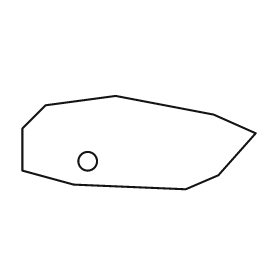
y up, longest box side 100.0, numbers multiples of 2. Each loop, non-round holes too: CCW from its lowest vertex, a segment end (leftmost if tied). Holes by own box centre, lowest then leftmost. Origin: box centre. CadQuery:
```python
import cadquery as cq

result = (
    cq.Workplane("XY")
    .moveTo(20.0, -20.0)
    .lineTo(34.0, -14.0)
    .lineTo(50.0, 4.0)
    .lineTo(32.0, 12.0)
    .lineTo(-10.0, 20.0)
    .lineTo(-40.0, 16.0)
    .lineTo(-50.0, 6.0)
    .lineTo(-50.0, -12.0)
    .lineTo(-28.0, -18.0)
    .close()
    .moveTo(-22.0, -8.0)
    .circle(4.0)
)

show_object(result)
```